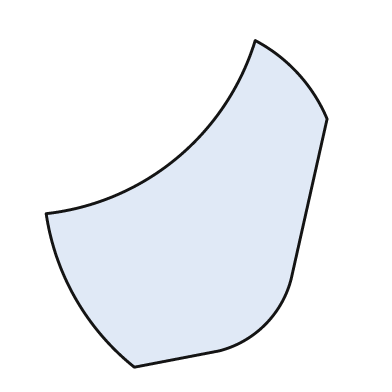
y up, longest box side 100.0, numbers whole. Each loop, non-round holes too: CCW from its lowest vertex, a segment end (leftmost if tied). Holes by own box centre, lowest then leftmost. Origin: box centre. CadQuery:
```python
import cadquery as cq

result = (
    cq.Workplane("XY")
    .moveTo(-16.0, -50.0)
    .lineTo(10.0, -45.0)
    .threePointArc((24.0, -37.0), (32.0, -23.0))
    .lineTo(43.0, 26.0)
    .threePointArc((34.0, 40.0), (21.0, 50.0))
    .threePointArc((-3.0, 14.0), (-43.0, -3.0))
    .threePointArc((-34.0, -29.0), (-16.0, -50.0))
    .close()
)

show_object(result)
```